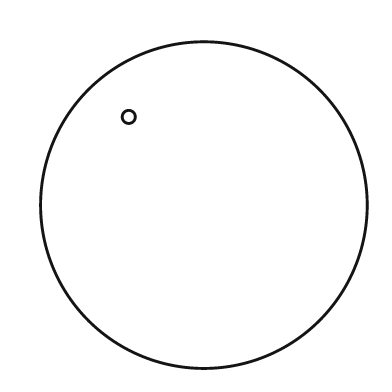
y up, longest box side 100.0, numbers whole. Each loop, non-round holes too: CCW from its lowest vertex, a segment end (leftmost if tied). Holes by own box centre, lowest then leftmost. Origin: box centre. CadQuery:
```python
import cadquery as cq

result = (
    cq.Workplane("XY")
    .moveTo(0.0, 0.0)
    .circle(50.0)
    .moveTo(-23.0, 27.0)
    .circle(2.0)
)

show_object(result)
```